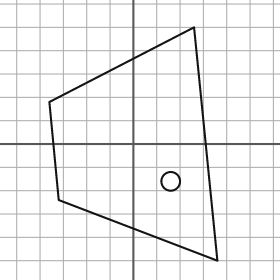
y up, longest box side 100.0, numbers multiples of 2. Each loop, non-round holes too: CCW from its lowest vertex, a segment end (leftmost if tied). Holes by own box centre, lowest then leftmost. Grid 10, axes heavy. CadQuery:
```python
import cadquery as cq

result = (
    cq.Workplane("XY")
    .moveTo(36.0, -50.0)
    .lineTo(26.0, 50.0)
    .lineTo(-36.0, 18.0)
    .lineTo(-32.0, -24.0)
    .close()
    .moveTo(16.0, -16.0)
    .circle(4.0)
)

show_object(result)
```